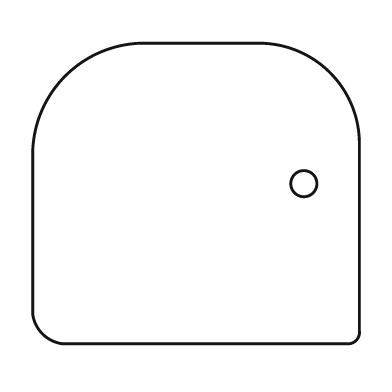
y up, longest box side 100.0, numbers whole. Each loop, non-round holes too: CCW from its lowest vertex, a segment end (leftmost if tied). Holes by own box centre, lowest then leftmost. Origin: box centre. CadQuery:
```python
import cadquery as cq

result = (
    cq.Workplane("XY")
    .moveTo(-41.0, -46.0)
    .lineTo(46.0, -46.0)
    .threePointArc((49.0, -45.0), (50.0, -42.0))
    .lineTo(50.0, 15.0)
    .threePointArc((41.0, 37.0), (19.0, 46.0))
    .lineTo(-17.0, 46.0)
    .threePointArc((-40.0, 36.0), (-50.0, 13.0))
    .lineTo(-50.0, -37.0)
    .threePointArc((-47.0, -43.0), (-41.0, -46.0))
    .close()
    .moveTo(33.0, 3.0)
    .circle(4.0)
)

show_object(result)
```